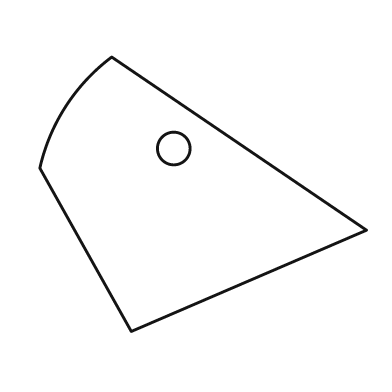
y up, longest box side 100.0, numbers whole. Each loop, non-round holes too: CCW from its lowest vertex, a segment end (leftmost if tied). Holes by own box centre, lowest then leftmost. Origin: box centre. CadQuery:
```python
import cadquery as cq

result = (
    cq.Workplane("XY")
    .moveTo(-22.0, -42.0)
    .lineTo(50.0, -11.0)
    .lineTo(-28.0, 42.0)
    .threePointArc((-42.0, 27.0), (-50.0, 8.0))
    .close()
    .moveTo(-9.0, 14.0)
    .circle(5.0)
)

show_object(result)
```